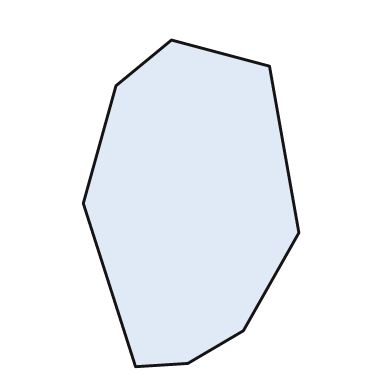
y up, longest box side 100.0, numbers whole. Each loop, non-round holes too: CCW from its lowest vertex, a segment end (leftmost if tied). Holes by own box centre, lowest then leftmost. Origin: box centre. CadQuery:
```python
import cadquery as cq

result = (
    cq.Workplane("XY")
    .moveTo(-17.0, -50.0)
    .lineTo(-1.0, -49.0)
    .lineTo(16.0, -39.0)
    .lineTo(33.0, -9.0)
    .lineTo(24.0, 42.0)
    .lineTo(-6.0, 50.0)
    .lineTo(-23.0, 36.0)
    .lineTo(-33.0, 0.0)
    .close()
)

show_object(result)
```